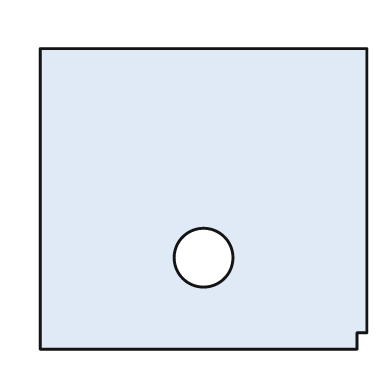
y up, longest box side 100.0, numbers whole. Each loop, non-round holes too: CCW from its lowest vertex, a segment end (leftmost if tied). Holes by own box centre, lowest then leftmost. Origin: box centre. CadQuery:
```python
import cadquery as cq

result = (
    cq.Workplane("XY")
    .moveTo(-50.0, -46.0)
    .lineTo(47.0, -46.0)
    .lineTo(47.0, -41.0)
    .lineTo(50.0, -41.0)
    .lineTo(50.0, 46.0)
    .lineTo(-50.0, 46.0)
    .close()
    .moveTo(0.0, -18.0)
    .circle(9.0)
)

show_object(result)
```